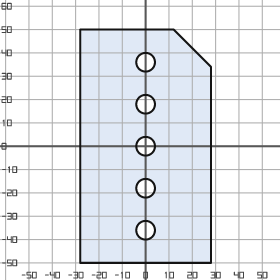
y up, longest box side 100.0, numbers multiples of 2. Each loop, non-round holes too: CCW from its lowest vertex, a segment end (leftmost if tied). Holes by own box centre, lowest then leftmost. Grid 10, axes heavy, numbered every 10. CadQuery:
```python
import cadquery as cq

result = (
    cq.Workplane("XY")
    .moveTo(-28.0, -50.0)
    .lineTo(28.0, -50.0)
    .lineTo(28.0, 34.0)
    .lineTo(12.0, 50.0)
    .lineTo(-28.0, 50.0)
    .close()
    .moveTo(0.0, -36.0)
    .circle(4.0)
    .moveTo(0.0, -18.0)
    .circle(4.0)
    .moveTo(0.0, 0.0)
    .circle(4.0)
    .moveTo(0.0, 18.0)
    .circle(4.0)
    .moveTo(0.0, 36.0)
    .circle(4.0)
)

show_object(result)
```